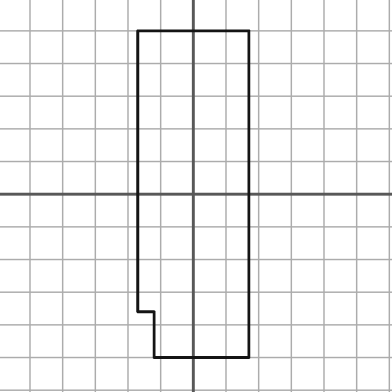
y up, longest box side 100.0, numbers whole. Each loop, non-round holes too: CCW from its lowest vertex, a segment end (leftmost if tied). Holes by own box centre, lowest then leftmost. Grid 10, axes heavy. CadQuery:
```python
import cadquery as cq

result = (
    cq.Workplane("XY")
    .moveTo(-12.0, -50.0)
    .lineTo(17.0, -50.0)
    .lineTo(17.0, 50.0)
    .lineTo(-17.0, 50.0)
    .lineTo(-17.0, -36.0)
    .lineTo(-12.0, -36.0)
    .close()
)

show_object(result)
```